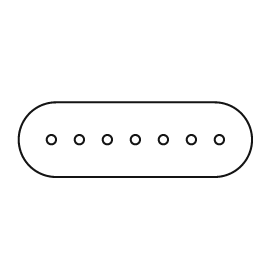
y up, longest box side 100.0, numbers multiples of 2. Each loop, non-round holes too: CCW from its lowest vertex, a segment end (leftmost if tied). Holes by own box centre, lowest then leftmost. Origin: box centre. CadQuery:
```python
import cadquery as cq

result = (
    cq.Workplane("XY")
    .moveTo(-34.0, -16.0)
    .lineTo(34.0, -16.0)
    .threePointArc((50.0, 0.0), (34.0, 16.0))
    .lineTo(-34.0, 16.0)
    .threePointArc((-50.0, 0.0), (-34.0, -16.0))
    .close()
    .moveTo(-36.0, 0.0)
    .circle(2.0)
    .moveTo(-24.0, 0.0)
    .circle(2.0)
    .moveTo(-12.0, 0.0)
    .circle(2.0)
    .moveTo(0.0, 0.0)
    .circle(2.0)
    .moveTo(12.0, 0.0)
    .circle(2.0)
    .moveTo(24.0, 0.0)
    .circle(2.0)
    .moveTo(36.0, 0.0)
    .circle(2.0)
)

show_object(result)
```